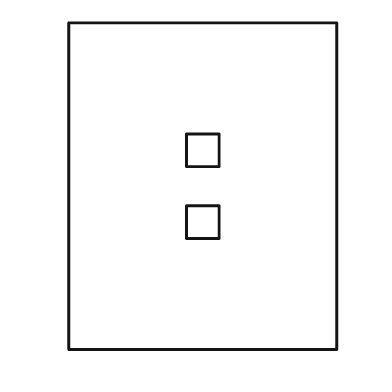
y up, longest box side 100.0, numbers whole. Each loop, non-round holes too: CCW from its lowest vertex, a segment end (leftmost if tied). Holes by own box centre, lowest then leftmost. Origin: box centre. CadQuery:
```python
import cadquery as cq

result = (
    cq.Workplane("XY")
    .moveTo(-41.0, -50.0)
    .lineTo(41.0, -50.0)
    .lineTo(41.0, 50.0)
    .lineTo(-41.0, 50.0)
    .close()
    .moveTo(-5.0, -16.0)
    .lineTo(5.0, -16.0)
    .lineTo(5.0, -6.0)
    .lineTo(-5.0, -6.0)
    .close()
    .moveTo(-5.0, 6.0)
    .lineTo(5.0, 6.0)
    .lineTo(5.0, 16.0)
    .lineTo(-5.0, 16.0)
    .close()
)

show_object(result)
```